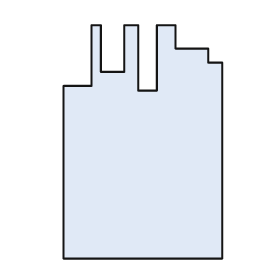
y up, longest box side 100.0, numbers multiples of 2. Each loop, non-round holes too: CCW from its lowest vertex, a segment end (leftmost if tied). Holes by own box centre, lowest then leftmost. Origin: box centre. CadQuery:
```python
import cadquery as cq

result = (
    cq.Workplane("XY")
    .moveTo(-34.0, -50.0)
    .lineTo(34.0, -50.0)
    .lineTo(34.0, 34.0)
    .lineTo(28.0, 34.0)
    .lineTo(28.0, 40.0)
    .lineTo(14.0, 40.0)
    .lineTo(14.0, 50.0)
    .lineTo(6.0, 50.0)
    .lineTo(6.0, 22.0)
    .lineTo(-2.0, 22.0)
    .lineTo(-2.0, 50.0)
    .lineTo(-8.0, 50.0)
    .lineTo(-8.0, 30.0)
    .lineTo(-18.0, 30.0)
    .lineTo(-18.0, 50.0)
    .lineTo(-22.0, 50.0)
    .lineTo(-22.0, 24.0)
    .lineTo(-34.0, 24.0)
    .close()
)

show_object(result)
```